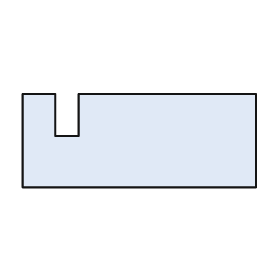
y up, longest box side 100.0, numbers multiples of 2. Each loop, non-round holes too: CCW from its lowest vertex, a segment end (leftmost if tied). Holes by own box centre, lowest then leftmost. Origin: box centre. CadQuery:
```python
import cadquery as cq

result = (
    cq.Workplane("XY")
    .moveTo(-50.0, -20.0)
    .lineTo(50.0, -20.0)
    .lineTo(50.0, 20.0)
    .lineTo(-26.0, 20.0)
    .lineTo(-26.0, 2.0)
    .lineTo(-36.0, 2.0)
    .lineTo(-36.0, 20.0)
    .lineTo(-50.0, 20.0)
    .close()
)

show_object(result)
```